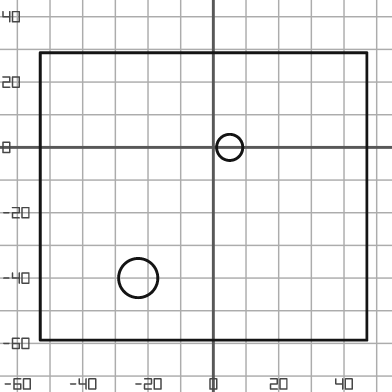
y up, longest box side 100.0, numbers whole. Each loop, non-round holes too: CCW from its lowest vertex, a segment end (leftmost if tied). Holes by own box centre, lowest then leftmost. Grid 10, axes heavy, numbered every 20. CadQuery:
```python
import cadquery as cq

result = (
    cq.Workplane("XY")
    .moveTo(-53.0, -59.0)
    .lineTo(47.0, -59.0)
    .lineTo(47.0, 29.0)
    .lineTo(-53.0, 29.0)
    .close()
    .moveTo(-23.0, -40.0)
    .circle(6.0)
    .moveTo(5.0, 0.0)
    .circle(4.0)
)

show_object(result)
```